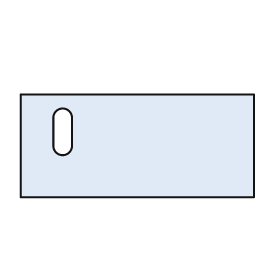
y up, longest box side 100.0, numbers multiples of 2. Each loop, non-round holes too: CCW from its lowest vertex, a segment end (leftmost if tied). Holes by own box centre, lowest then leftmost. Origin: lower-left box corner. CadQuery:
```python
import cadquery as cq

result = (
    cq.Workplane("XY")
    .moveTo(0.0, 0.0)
    .lineTo(100.0, 0.0)
    .lineTo(100.0, 44.0)
    .lineTo(0.0, 44.0)
    .close()
    .moveTo(14.0, 22.0)
    .threePointArc((18.0, 18.0), (22.0, 22.0))
    .lineTo(22.0, 34.0)
    .threePointArc((18.0, 38.0), (14.0, 34.0))
    .close()
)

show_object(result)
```